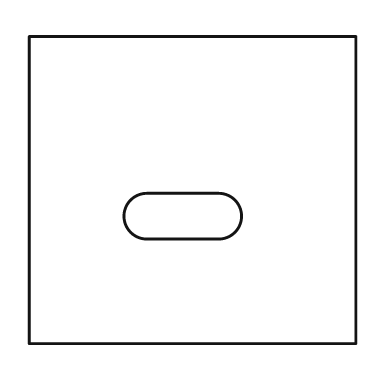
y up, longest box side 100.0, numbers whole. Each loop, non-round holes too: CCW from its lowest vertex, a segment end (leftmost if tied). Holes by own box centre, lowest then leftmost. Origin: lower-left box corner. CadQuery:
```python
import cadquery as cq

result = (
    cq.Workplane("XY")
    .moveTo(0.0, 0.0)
    .lineTo(100.0, 0.0)
    .lineTo(100.0, 94.0)
    .lineTo(0.0, 94.0)
    .close()
    .moveTo(36.0, 32.0)
    .lineTo(58.0, 32.0)
    .threePointArc((65.0, 39.0), (58.0, 46.0))
    .lineTo(36.0, 46.0)
    .threePointArc((29.0, 39.0), (36.0, 32.0))
    .close()
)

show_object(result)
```